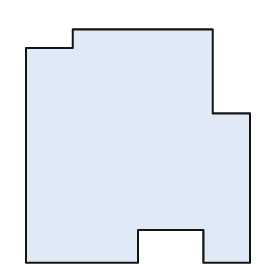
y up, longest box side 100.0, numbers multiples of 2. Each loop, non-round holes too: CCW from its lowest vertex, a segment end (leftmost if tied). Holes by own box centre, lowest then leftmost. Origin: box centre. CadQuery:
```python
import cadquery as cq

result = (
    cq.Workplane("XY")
    .moveTo(-48.0, -50.0)
    .lineTo(0.0, -50.0)
    .lineTo(0.0, -36.0)
    .lineTo(28.0, -36.0)
    .lineTo(28.0, -50.0)
    .lineTo(48.0, -50.0)
    .lineTo(48.0, 14.0)
    .lineTo(32.0, 14.0)
    .lineTo(32.0, 50.0)
    .lineTo(-28.0, 50.0)
    .lineTo(-28.0, 42.0)
    .lineTo(-48.0, 42.0)
    .close()
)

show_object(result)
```